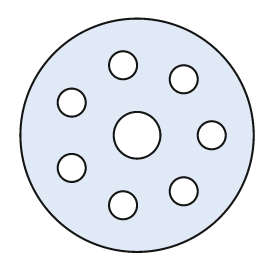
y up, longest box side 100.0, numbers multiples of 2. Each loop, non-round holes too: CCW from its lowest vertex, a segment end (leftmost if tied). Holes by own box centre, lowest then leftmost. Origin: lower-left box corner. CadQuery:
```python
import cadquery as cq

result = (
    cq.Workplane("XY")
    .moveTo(50.0, 50.0)
    .circle(50.0)
    .moveTo(44.0, 20.0)
    .circle(6.0)
    .moveTo(70.0, 26.0)
    .circle(6.0)
    .moveTo(22.0, 36.0)
    .circle(6.0)
    .moveTo(50.0, 50.0)
    .circle(10.0)
    .moveTo(82.0, 50.0)
    .circle(6.0)
    .moveTo(22.0, 64.0)
    .circle(6.0)
    .moveTo(70.0, 74.0)
    .circle(6.0)
    .moveTo(44.0, 80.0)
    .circle(6.0)
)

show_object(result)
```